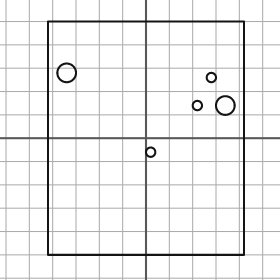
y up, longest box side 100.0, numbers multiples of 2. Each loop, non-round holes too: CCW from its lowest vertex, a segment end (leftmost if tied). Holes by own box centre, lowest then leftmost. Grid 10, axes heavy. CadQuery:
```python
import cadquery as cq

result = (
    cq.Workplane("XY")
    .moveTo(-42.0, -50.0)
    .lineTo(42.0, -50.0)
    .lineTo(42.0, 50.0)
    .lineTo(-42.0, 50.0)
    .close()
    .moveTo(2.0, -6.0)
    .circle(2.0)
    .moveTo(22.0, 14.0)
    .circle(2.0)
    .moveTo(34.0, 14.0)
    .circle(4.0)
    .moveTo(28.0, 26.0)
    .circle(2.0)
    .moveTo(-34.0, 28.0)
    .circle(4.0)
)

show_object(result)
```